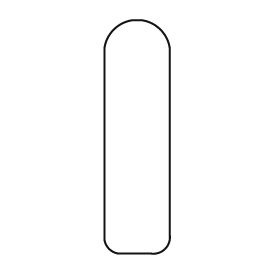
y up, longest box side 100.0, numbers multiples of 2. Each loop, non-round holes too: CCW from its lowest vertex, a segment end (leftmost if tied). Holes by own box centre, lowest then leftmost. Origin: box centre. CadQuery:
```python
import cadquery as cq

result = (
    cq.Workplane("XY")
    .moveTo(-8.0, -50.0)
    .lineTo(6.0, -50.0)
    .threePointArc((12.0, -48.0), (14.0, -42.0))
    .lineTo(14.0, 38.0)
    .threePointArc((10.0, 46.0), (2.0, 50.0))
    .lineTo(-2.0, 50.0)
    .threePointArc((-10.0, 46.0), (-14.0, 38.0))
    .lineTo(-14.0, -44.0)
    .threePointArc((-12.0, -48.0), (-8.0, -50.0))
    .close()
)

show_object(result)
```